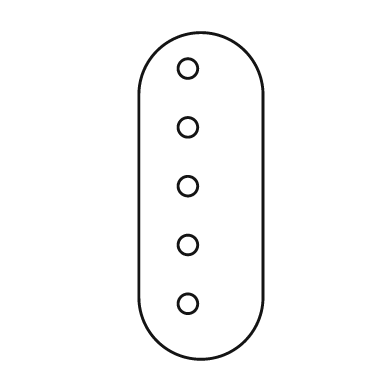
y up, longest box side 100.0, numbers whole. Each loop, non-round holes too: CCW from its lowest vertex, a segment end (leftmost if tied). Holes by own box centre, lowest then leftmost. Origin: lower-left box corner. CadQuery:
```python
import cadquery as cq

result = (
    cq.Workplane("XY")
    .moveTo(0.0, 19.0)
    .threePointArc((19.0, 0.0), (38.0, 19.0))
    .lineTo(38.0, 81.0)
    .threePointArc((19.0, 100.0), (0.0, 81.0))
    .close()
    .moveTo(15.0, 17.0)
    .circle(3.0)
    .moveTo(15.0, 35.0)
    .circle(3.0)
    .moveTo(15.0, 53.0)
    .circle(3.0)
    .moveTo(15.0, 71.0)
    .circle(3.0)
    .moveTo(15.0, 89.0)
    .circle(3.0)
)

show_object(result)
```